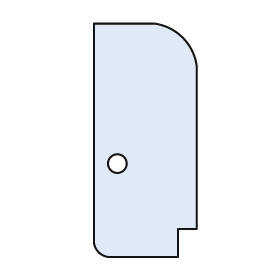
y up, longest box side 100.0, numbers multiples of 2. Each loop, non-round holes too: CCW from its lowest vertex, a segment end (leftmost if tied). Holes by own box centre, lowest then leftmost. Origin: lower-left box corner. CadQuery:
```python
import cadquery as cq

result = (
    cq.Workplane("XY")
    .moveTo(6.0, 0.0)
    .lineTo(36.0, 0.0)
    .lineTo(36.0, 12.0)
    .lineTo(44.0, 12.0)
    .lineTo(44.0, 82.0)
    .threePointArc((38.0, 94.0), (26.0, 100.0))
    .lineTo(0.0, 100.0)
    .lineTo(0.0, 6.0)
    .threePointArc((2.0, 2.0), (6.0, 0.0))
    .close()
    .moveTo(10.0, 40.0)
    .circle(4.0)
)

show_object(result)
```